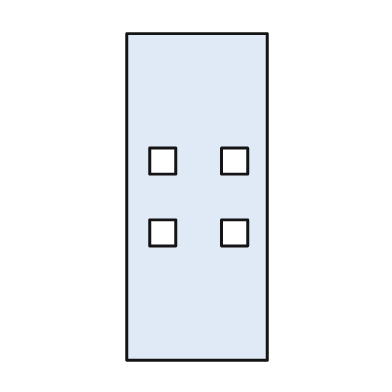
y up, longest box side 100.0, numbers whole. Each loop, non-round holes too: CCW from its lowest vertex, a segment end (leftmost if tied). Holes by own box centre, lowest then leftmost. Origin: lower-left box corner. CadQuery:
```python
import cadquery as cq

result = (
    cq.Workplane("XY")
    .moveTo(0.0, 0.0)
    .lineTo(43.0, 0.0)
    .lineTo(43.0, 100.0)
    .lineTo(0.0, 100.0)
    .close()
    .moveTo(7.0, 35.0)
    .lineTo(15.0, 35.0)
    .lineTo(15.0, 43.0)
    .lineTo(7.0, 43.0)
    .close()
    .moveTo(29.0, 35.0)
    .lineTo(37.0, 35.0)
    .lineTo(37.0, 43.0)
    .lineTo(29.0, 43.0)
    .close()
    .moveTo(7.0, 57.0)
    .lineTo(15.0, 57.0)
    .lineTo(15.0, 65.0)
    .lineTo(7.0, 65.0)
    .close()
    .moveTo(29.0, 57.0)
    .lineTo(37.0, 57.0)
    .lineTo(37.0, 65.0)
    .lineTo(29.0, 65.0)
    .close()
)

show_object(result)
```